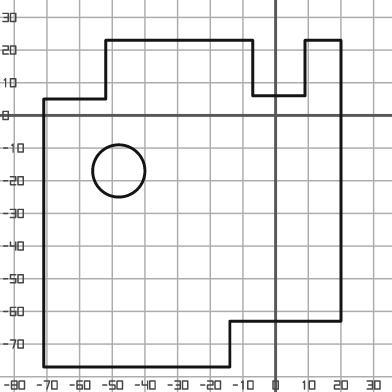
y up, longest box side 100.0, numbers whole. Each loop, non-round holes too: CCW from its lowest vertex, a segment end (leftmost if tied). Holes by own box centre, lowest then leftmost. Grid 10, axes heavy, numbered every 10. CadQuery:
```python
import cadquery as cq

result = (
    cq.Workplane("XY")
    .moveTo(-71.0, -77.0)
    .lineTo(-14.0, -77.0)
    .lineTo(-14.0, -63.0)
    .lineTo(20.0, -63.0)
    .lineTo(20.0, 23.0)
    .lineTo(9.0, 23.0)
    .lineTo(9.0, 6.0)
    .lineTo(-7.0, 6.0)
    .lineTo(-7.0, 23.0)
    .lineTo(-52.0, 23.0)
    .lineTo(-52.0, 5.0)
    .lineTo(-71.0, 5.0)
    .close()
    .moveTo(-48.0, -17.0)
    .circle(8.0)
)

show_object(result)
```